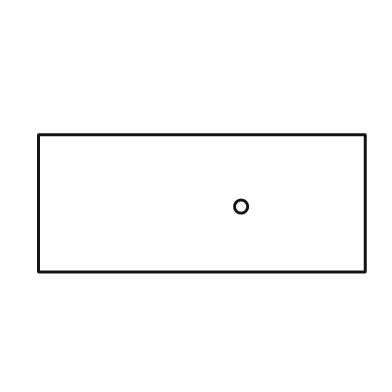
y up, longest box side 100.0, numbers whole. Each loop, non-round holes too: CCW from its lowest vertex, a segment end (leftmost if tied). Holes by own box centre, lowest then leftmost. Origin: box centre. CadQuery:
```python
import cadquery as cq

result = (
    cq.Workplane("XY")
    .moveTo(-50.0, -21.0)
    .lineTo(50.0, -21.0)
    .lineTo(50.0, 21.0)
    .lineTo(-50.0, 21.0)
    .close()
    .moveTo(12.0, -1.0)
    .circle(2.0)
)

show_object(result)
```